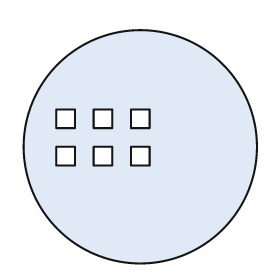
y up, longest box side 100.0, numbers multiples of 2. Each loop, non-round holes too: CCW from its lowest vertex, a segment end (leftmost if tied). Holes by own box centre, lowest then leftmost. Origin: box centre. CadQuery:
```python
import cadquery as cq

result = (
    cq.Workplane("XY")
    .moveTo(0.0, 0.0)
    .circle(50.0)
    .moveTo(-36.0, -8.0)
    .lineTo(-28.0, -8.0)
    .lineTo(-28.0, 0.0)
    .lineTo(-36.0, 0.0)
    .close()
    .moveTo(-20.0, -8.0)
    .lineTo(-12.0, -8.0)
    .lineTo(-12.0, 0.0)
    .lineTo(-20.0, 0.0)
    .close()
    .moveTo(-4.0, -8.0)
    .lineTo(4.0, -8.0)
    .lineTo(4.0, 0.0)
    .lineTo(-4.0, 0.0)
    .close()
    .moveTo(-36.0, 8.0)
    .lineTo(-28.0, 8.0)
    .lineTo(-28.0, 16.0)
    .lineTo(-36.0, 16.0)
    .close()
    .moveTo(-20.0, 8.0)
    .lineTo(-12.0, 8.0)
    .lineTo(-12.0, 16.0)
    .lineTo(-20.0, 16.0)
    .close()
    .moveTo(-4.0, 8.0)
    .lineTo(4.0, 8.0)
    .lineTo(4.0, 16.0)
    .lineTo(-4.0, 16.0)
    .close()
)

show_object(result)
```